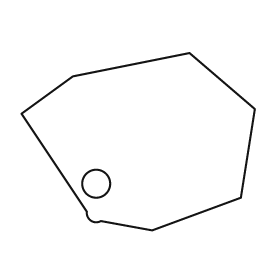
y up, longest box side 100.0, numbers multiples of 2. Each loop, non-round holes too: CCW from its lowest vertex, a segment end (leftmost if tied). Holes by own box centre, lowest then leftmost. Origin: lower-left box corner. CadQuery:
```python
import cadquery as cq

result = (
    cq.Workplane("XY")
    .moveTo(56.0, 0.0)
    .lineTo(94.0, 14.0)
    .lineTo(100.0, 52.0)
    .lineTo(72.0, 76.0)
    .lineTo(22.0, 66.0)
    .lineTo(0.0, 50.0)
    .lineTo(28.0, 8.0)
    .threePointArc((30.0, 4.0), (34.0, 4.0))
    .close()
    .moveTo(32.0, 20.0)
    .circle(6.0)
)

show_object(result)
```